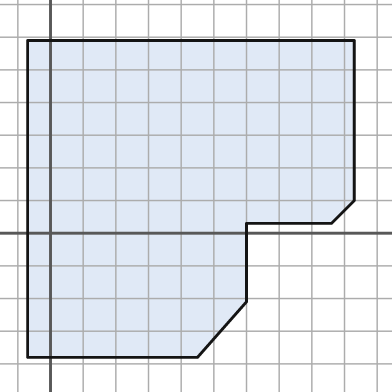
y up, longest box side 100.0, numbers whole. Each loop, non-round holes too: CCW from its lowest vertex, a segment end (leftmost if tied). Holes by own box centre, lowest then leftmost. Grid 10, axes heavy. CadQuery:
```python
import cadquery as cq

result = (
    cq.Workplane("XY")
    .moveTo(-7.0, -38.0)
    .lineTo(45.0, -38.0)
    .lineTo(60.0, -21.0)
    .lineTo(60.0, 3.0)
    .lineTo(86.0, 3.0)
    .lineTo(93.0, 10.0)
    .lineTo(93.0, 59.0)
    .lineTo(-7.0, 59.0)
    .close()
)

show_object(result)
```